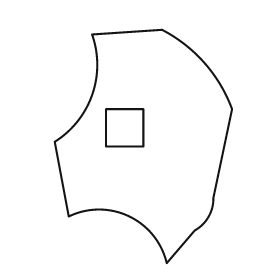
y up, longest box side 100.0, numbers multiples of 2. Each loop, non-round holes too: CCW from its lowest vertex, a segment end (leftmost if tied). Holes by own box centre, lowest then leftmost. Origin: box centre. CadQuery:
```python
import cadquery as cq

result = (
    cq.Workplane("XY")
    .moveTo(10.0, -50.0)
    .lineTo(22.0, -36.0)
    .threePointArc((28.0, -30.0), (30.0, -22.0))
    .lineTo(38.0, 16.0)
    .threePointArc((26.0, 36.0), (8.0, 50.0))
    .lineTo(-22.0, 48.0)
    .threePointArc((-22.0, 22.0), (-38.0, 2.0))
    .lineTo(-32.0, -30.0)
    .threePointArc((-6.0, -30.0), (10.0, -50.0))
    .close()
    .moveTo(-16.0, 0.0)
    .lineTo(0.0, 0.0)
    .lineTo(0.0, 16.0)
    .lineTo(-16.0, 16.0)
    .close()
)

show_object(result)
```